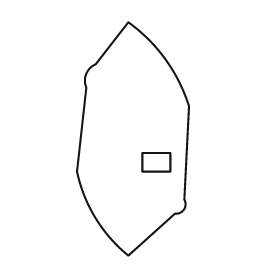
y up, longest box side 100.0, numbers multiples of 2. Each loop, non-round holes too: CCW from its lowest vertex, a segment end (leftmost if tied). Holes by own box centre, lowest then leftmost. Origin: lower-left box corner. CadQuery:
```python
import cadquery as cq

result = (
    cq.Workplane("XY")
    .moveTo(22.0, 0.0)
    .lineTo(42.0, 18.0)
    .threePointArc((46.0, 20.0), (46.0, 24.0))
    .lineTo(48.0, 64.0)
    .threePointArc((38.0, 84.0), (22.0, 100.0))
    .lineTo(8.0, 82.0)
    .threePointArc((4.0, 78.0), (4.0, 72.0))
    .lineTo(0.0, 36.0)
    .threePointArc((8.0, 16.0), (22.0, 0.0))
    .close()
    .moveTo(28.0, 36.0)
    .lineTo(40.0, 36.0)
    .lineTo(40.0, 44.0)
    .lineTo(28.0, 44.0)
    .close()
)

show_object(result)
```